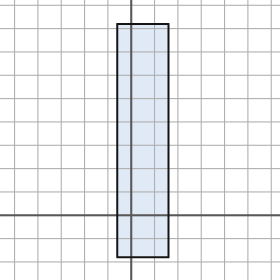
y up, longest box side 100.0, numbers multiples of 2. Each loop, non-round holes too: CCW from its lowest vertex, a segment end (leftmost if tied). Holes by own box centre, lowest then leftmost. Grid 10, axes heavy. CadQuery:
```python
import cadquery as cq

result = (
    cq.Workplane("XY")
    .moveTo(-6.0, -18.0)
    .lineTo(16.0, -18.0)
    .lineTo(16.0, 82.0)
    .lineTo(-6.0, 82.0)
    .close()
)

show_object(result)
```